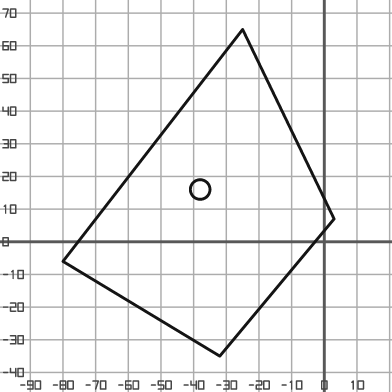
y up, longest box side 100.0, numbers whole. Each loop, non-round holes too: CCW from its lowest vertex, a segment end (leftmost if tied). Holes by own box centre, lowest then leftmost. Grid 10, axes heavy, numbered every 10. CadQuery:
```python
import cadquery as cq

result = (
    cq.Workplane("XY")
    .moveTo(-32.0, -35.0)
    .lineTo(3.0, 7.0)
    .lineTo(-25.0, 65.0)
    .lineTo(-80.0, -6.0)
    .close()
    .moveTo(-38.0, 16.0)
    .circle(3.0)
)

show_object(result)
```